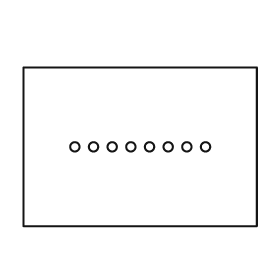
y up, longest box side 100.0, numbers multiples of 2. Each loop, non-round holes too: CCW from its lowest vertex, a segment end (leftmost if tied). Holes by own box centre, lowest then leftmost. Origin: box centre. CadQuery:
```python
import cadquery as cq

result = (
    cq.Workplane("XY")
    .moveTo(-50.0, -34.0)
    .lineTo(50.0, -34.0)
    .lineTo(50.0, 34.0)
    .lineTo(-50.0, 34.0)
    .close()
    .moveTo(-28.0, 0.0)
    .circle(2.0)
    .moveTo(-20.0, 0.0)
    .circle(2.0)
    .moveTo(-12.0, 0.0)
    .circle(2.0)
    .moveTo(-4.0, 0.0)
    .circle(2.0)
    .moveTo(4.0, 0.0)
    .circle(2.0)
    .moveTo(12.0, 0.0)
    .circle(2.0)
    .moveTo(20.0, 0.0)
    .circle(2.0)
    .moveTo(28.0, 0.0)
    .circle(2.0)
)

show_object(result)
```